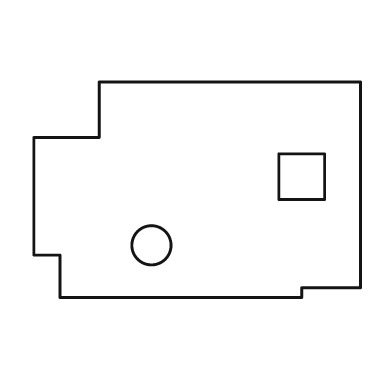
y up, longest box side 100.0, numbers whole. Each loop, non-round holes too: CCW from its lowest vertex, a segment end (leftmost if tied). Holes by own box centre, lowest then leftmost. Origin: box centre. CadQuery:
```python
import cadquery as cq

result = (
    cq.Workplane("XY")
    .moveTo(-42.0, -33.0)
    .lineTo(32.0, -33.0)
    .lineTo(32.0, -30.0)
    .lineTo(50.0, -30.0)
    .lineTo(50.0, 33.0)
    .lineTo(-30.0, 33.0)
    .lineTo(-30.0, 16.0)
    .lineTo(-50.0, 16.0)
    .lineTo(-50.0, -20.0)
    .lineTo(-42.0, -20.0)
    .close()
    .moveTo(-14.0, -17.0)
    .circle(6.0)
    .moveTo(25.0, -3.0)
    .lineTo(39.0, -3.0)
    .lineTo(39.0, 11.0)
    .lineTo(25.0, 11.0)
    .close()
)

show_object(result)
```